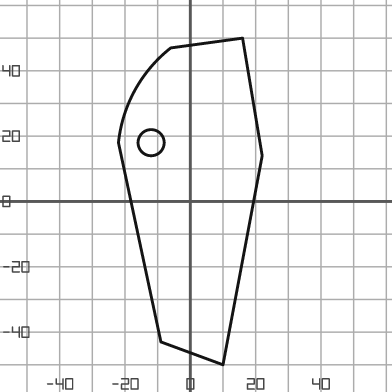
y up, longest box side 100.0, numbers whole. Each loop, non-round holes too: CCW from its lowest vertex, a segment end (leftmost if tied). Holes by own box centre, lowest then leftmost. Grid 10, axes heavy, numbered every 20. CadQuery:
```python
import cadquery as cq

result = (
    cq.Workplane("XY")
    .moveTo(10.0, -50.0)
    .lineTo(22.0, 14.0)
    .lineTo(16.0, 50.0)
    .lineTo(-6.0, 47.0)
    .threePointArc((-17.0, 34.0), (-22.0, 18.0))
    .lineTo(-9.0, -43.0)
    .close()
    .moveTo(-12.0, 18.0)
    .circle(4.0)
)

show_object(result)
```